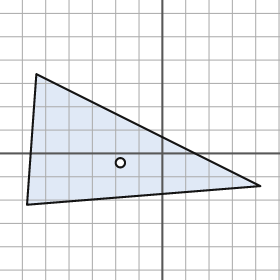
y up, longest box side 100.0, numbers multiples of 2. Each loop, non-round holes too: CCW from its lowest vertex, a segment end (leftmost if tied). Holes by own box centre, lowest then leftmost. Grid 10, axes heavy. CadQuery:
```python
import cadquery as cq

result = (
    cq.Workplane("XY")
    .moveTo(-58.0, -22.0)
    .lineTo(42.0, -14.0)
    .lineTo(-54.0, 34.0)
    .close()
    .moveTo(-18.0, -4.0)
    .circle(2.0)
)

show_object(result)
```